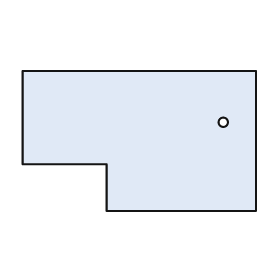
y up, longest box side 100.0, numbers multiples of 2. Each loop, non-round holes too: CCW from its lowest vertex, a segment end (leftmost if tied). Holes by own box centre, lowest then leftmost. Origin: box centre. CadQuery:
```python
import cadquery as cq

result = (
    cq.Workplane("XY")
    .moveTo(-14.0, -30.0)
    .lineTo(50.0, -30.0)
    .lineTo(50.0, 30.0)
    .lineTo(-50.0, 30.0)
    .lineTo(-50.0, -10.0)
    .lineTo(-14.0, -10.0)
    .close()
    .moveTo(36.0, 8.0)
    .circle(2.0)
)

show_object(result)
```